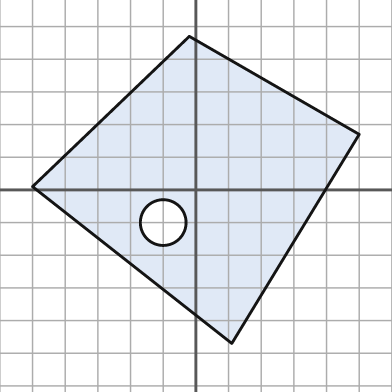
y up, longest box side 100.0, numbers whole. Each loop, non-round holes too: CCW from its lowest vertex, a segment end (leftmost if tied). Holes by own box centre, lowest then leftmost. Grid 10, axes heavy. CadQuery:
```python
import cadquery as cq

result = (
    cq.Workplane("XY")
    .moveTo(11.0, -47.0)
    .lineTo(50.0, 17.0)
    .lineTo(-2.0, 47.0)
    .lineTo(-50.0, 1.0)
    .close()
    .moveTo(-10.0, -10.0)
    .circle(7.0)
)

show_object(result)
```